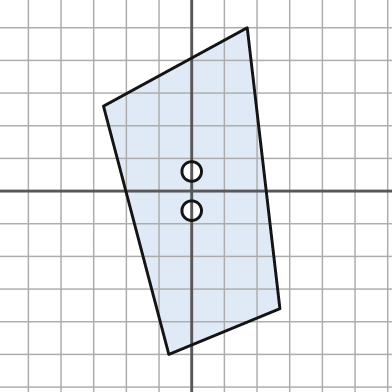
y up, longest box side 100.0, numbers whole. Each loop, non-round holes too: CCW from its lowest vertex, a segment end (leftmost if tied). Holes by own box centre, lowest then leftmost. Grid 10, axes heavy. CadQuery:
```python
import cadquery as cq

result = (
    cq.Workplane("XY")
    .moveTo(-7.0, -50.0)
    .lineTo(27.0, -36.0)
    .lineTo(17.0, 50.0)
    .lineTo(-27.0, 26.0)
    .close()
    .moveTo(0.0, -6.0)
    .circle(3.0)
    .moveTo(0.0, 6.0)
    .circle(3.0)
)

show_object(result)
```